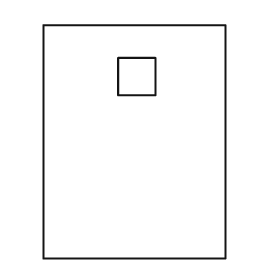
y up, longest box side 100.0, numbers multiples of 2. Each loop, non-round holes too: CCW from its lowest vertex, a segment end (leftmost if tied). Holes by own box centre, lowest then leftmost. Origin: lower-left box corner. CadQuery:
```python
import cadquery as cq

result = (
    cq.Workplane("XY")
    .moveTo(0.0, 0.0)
    .lineTo(78.0, 0.0)
    .lineTo(78.0, 100.0)
    .lineTo(0.0, 100.0)
    .close()
    .moveTo(32.0, 70.0)
    .lineTo(48.0, 70.0)
    .lineTo(48.0, 86.0)
    .lineTo(32.0, 86.0)
    .close()
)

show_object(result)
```